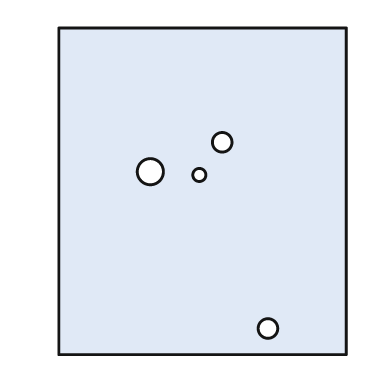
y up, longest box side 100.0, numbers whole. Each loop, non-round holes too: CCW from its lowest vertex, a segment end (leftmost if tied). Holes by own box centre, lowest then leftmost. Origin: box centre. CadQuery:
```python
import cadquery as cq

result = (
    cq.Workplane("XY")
    .moveTo(-44.0, -50.0)
    .lineTo(44.0, -50.0)
    .lineTo(44.0, 50.0)
    .lineTo(-44.0, 50.0)
    .close()
    .moveTo(20.0, -42.0)
    .circle(3.0)
    .moveTo(-1.0, 5.0)
    .circle(2.0)
    .moveTo(-16.0, 6.0)
    .circle(4.0)
    .moveTo(6.0, 15.0)
    .circle(3.0)
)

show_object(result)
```